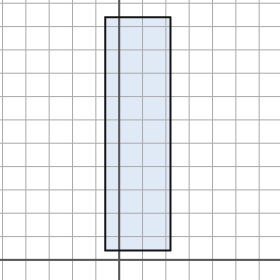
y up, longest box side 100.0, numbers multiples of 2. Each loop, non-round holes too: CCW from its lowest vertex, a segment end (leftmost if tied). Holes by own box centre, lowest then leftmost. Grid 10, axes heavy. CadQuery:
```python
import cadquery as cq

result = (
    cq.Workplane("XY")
    .moveTo(-6.0, 4.0)
    .lineTo(22.0, 4.0)
    .lineTo(22.0, 104.0)
    .lineTo(-6.0, 104.0)
    .close()
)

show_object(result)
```